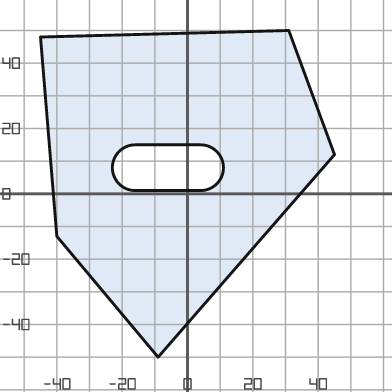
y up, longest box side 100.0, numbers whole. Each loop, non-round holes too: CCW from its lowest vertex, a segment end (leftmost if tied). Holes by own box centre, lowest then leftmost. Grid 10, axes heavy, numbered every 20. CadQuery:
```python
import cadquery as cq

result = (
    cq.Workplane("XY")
    .moveTo(-9.0, -50.0)
    .lineTo(45.0, 12.0)
    .lineTo(31.0, 50.0)
    .lineTo(-45.0, 48.0)
    .lineTo(-40.0, -13.0)
    .close()
    .moveTo(-16.0, 1.0)
    .lineTo(4.0, 1.0)
    .threePointArc((11.0, 8.0), (4.0, 15.0))
    .lineTo(-16.0, 15.0)
    .threePointArc((-23.0, 8.0), (-16.0, 1.0))
    .close()
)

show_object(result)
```